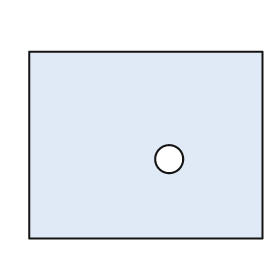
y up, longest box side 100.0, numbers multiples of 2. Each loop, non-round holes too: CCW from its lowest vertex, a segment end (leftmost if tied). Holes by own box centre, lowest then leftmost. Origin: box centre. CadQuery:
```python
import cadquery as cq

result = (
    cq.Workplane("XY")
    .moveTo(-50.0, -40.0)
    .lineTo(50.0, -40.0)
    .lineTo(50.0, 40.0)
    .lineTo(-50.0, 40.0)
    .close()
    .moveTo(10.0, -6.0)
    .circle(6.0)
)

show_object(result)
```